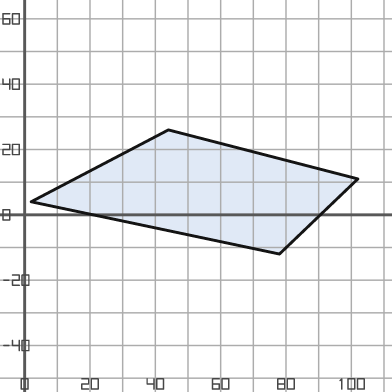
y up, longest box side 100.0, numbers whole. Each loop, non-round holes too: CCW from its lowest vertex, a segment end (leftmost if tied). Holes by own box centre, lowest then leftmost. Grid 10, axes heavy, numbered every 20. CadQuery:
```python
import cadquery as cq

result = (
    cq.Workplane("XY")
    .moveTo(78.0, -12.0)
    .lineTo(102.0, 11.0)
    .lineTo(44.0, 26.0)
    .lineTo(2.0, 4.0)
    .close()
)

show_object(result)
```